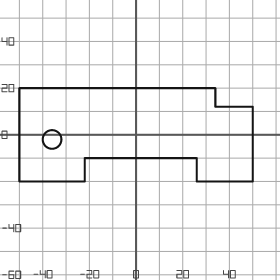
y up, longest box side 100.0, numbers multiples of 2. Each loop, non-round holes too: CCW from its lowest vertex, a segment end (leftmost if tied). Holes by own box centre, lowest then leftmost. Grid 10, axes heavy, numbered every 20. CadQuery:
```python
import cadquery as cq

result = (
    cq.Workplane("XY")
    .moveTo(-50.0, -20.0)
    .lineTo(-22.0, -20.0)
    .lineTo(-22.0, -10.0)
    .lineTo(26.0, -10.0)
    .lineTo(26.0, -20.0)
    .lineTo(50.0, -20.0)
    .lineTo(50.0, 12.0)
    .lineTo(34.0, 12.0)
    .lineTo(34.0, 20.0)
    .lineTo(-50.0, 20.0)
    .close()
    .moveTo(-36.0, -2.0)
    .circle(4.0)
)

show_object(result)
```